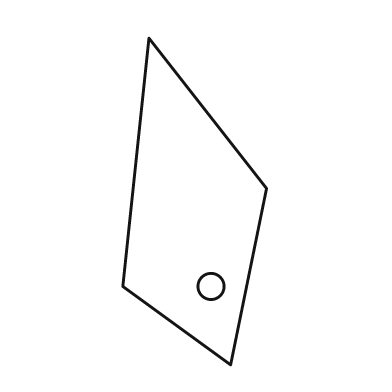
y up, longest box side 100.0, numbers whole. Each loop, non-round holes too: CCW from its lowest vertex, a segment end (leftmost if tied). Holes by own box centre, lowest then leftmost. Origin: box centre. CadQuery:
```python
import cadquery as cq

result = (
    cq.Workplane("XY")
    .moveTo(11.0, -50.0)
    .lineTo(22.0, 4.0)
    .lineTo(-14.0, 50.0)
    .lineTo(-22.0, -26.0)
    .close()
    .moveTo(5.0, -26.0)
    .circle(4.0)
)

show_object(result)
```